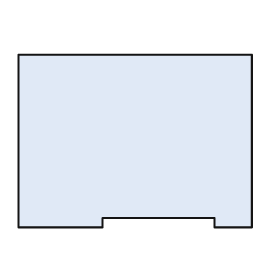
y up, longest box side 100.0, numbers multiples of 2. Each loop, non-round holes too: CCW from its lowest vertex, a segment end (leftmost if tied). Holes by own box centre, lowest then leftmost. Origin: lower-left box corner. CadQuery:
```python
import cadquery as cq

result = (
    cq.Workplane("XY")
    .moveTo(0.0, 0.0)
    .lineTo(36.0, 0.0)
    .lineTo(36.0, 4.0)
    .lineTo(84.0, 4.0)
    .lineTo(84.0, 0.0)
    .lineTo(100.0, 0.0)
    .lineTo(100.0, 74.0)
    .lineTo(0.0, 74.0)
    .close()
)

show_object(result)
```